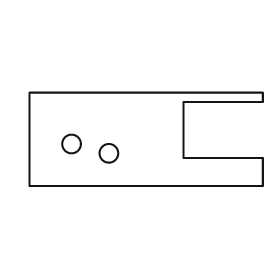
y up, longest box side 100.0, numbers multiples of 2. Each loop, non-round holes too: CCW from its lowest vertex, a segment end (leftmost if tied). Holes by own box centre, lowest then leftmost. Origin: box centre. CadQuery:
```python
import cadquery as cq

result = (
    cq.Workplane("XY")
    .moveTo(-50.0, -20.0)
    .lineTo(50.0, -20.0)
    .lineTo(50.0, -8.0)
    .lineTo(16.0, -8.0)
    .lineTo(16.0, 16.0)
    .lineTo(50.0, 16.0)
    .lineTo(50.0, 20.0)
    .lineTo(-50.0, 20.0)
    .close()
    .moveTo(-16.0, -6.0)
    .circle(4.0)
    .moveTo(-32.0, -2.0)
    .circle(4.0)
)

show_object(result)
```